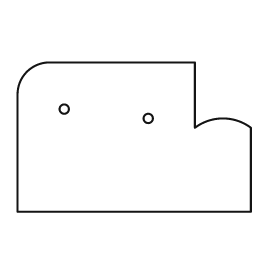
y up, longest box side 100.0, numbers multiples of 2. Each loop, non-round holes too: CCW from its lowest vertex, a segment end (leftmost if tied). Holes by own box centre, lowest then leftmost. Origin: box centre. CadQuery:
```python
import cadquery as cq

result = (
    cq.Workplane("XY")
    .moveTo(-50.0, -32.0)
    .lineTo(50.0, -32.0)
    .lineTo(50.0, 4.0)
    .threePointArc((38.0, 8.0), (26.0, 4.0))
    .lineTo(26.0, 32.0)
    .lineTo(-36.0, 32.0)
    .threePointArc((-46.0, 28.0), (-50.0, 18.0))
    .close()
    .moveTo(6.0, 8.0)
    .circle(2.0)
    .moveTo(-30.0, 12.0)
    .circle(2.0)
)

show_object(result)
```